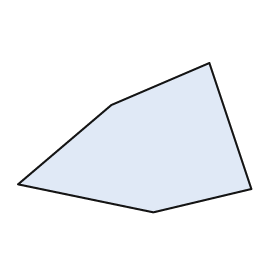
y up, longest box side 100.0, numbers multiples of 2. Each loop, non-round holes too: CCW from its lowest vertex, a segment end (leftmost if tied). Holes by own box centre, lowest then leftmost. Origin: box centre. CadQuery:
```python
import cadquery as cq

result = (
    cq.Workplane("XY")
    .moveTo(8.0, -32.0)
    .lineTo(50.0, -22.0)
    .lineTo(32.0, 32.0)
    .lineTo(-10.0, 14.0)
    .lineTo(-50.0, -20.0)
    .close()
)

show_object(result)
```